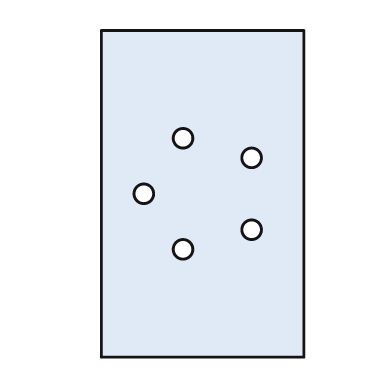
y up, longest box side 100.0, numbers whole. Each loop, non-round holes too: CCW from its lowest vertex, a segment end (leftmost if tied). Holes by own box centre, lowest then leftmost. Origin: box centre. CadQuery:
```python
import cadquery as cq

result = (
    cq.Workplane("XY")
    .moveTo(-31.0, -50.0)
    .lineTo(31.0, -50.0)
    .lineTo(31.0, 50.0)
    .lineTo(-31.0, 50.0)
    .close()
    .moveTo(-6.0, -17.0)
    .circle(3.0)
    .moveTo(15.0, -11.0)
    .circle(3.0)
    .moveTo(-18.0, 0.0)
    .circle(3.0)
    .moveTo(15.0, 11.0)
    .circle(3.0)
    .moveTo(-6.0, 17.0)
    .circle(3.0)
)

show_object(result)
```